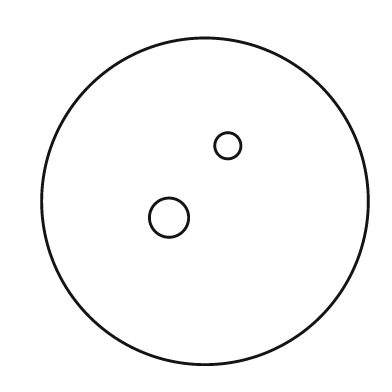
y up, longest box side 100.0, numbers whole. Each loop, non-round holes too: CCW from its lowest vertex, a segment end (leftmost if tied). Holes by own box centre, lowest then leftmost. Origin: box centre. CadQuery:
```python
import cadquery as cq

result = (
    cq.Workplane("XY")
    .moveTo(0.0, 0.0)
    .circle(50.0)
    .moveTo(-11.0, -5.0)
    .circle(6.0)
    .moveTo(7.0, 17.0)
    .circle(4.0)
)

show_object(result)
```